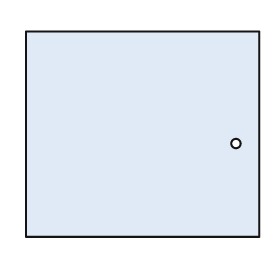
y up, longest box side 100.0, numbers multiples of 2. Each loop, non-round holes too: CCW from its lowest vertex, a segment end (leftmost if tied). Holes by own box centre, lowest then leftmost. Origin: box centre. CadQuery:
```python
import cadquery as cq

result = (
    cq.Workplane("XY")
    .moveTo(-50.0, -44.0)
    .lineTo(50.0, -44.0)
    .lineTo(50.0, 44.0)
    .lineTo(-50.0, 44.0)
    .close()
    .moveTo(40.0, -4.0)
    .circle(2.0)
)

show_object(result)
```